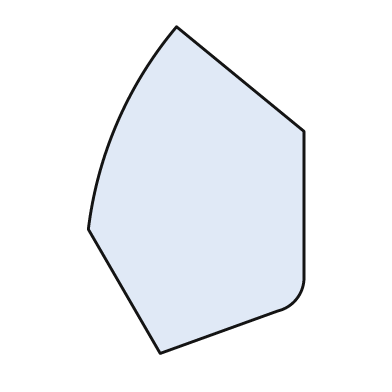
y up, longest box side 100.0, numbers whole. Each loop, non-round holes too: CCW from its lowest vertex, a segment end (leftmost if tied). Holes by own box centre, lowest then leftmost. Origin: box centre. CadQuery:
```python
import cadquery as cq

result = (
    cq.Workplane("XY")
    .moveTo(-11.0, -50.0)
    .lineTo(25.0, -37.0)
    .threePointArc((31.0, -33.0), (33.0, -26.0))
    .lineTo(33.0, 18.0)
    .lineTo(-6.0, 50.0)
    .threePointArc((-24.0, 21.0), (-33.0, -12.0))
    .close()
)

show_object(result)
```